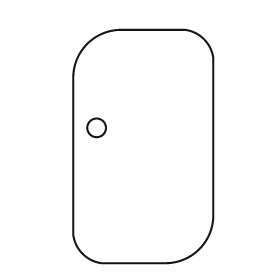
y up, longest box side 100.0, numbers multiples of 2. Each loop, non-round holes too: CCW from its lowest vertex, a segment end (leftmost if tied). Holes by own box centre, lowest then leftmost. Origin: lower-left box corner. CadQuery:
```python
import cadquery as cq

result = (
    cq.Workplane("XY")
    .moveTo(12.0, 0.0)
    .lineTo(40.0, 0.0)
    .threePointArc((54.0, 6.0), (60.0, 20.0))
    .lineTo(60.0, 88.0)
    .threePointArc((56.0, 96.0), (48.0, 100.0))
    .lineTo(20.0, 100.0)
    .threePointArc((6.0, 94.0), (0.0, 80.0))
    .lineTo(0.0, 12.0)
    .threePointArc((4.0, 4.0), (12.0, 0.0))
    .close()
    .moveTo(10.0, 58.0)
    .circle(4.0)
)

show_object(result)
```